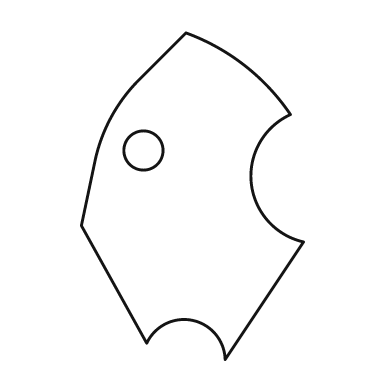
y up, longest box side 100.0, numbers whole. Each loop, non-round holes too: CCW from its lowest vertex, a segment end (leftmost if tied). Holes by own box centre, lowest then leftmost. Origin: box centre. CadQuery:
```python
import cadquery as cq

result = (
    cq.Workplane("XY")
    .moveTo(10.0, -50.0)
    .lineTo(34.0, -14.0)
    .threePointArc((18.0, 4.0), (30.0, 25.0))
    .threePointArc((16.0, 40.0), (-2.0, 50.0))
    .lineTo(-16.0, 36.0)
    .threePointArc((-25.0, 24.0), (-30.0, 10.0))
    .lineTo(-34.0, -9.0)
    .lineTo(-14.0, -45.0)
    .threePointArc((0.0, -38.0), (10.0, -50.0))
    .close()
    .moveTo(-15.0, 14.0)
    .circle(6.0)
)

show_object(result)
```